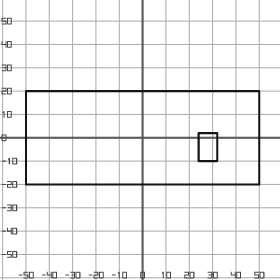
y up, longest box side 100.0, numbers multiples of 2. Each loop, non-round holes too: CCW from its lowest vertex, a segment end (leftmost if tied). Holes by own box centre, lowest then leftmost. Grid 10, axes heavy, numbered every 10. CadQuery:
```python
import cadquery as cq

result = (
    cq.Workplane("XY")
    .moveTo(-50.0, -20.0)
    .lineTo(50.0, -20.0)
    .lineTo(50.0, 20.0)
    .lineTo(-50.0, 20.0)
    .close()
    .moveTo(24.0, -10.0)
    .lineTo(32.0, -10.0)
    .lineTo(32.0, 2.0)
    .lineTo(24.0, 2.0)
    .close()
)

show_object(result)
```